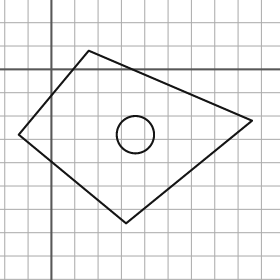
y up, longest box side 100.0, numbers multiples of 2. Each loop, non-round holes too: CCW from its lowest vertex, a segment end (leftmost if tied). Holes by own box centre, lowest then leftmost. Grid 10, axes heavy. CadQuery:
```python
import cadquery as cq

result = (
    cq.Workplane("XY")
    .moveTo(32.0, -66.0)
    .lineTo(86.0, -22.0)
    .lineTo(16.0, 8.0)
    .lineTo(-14.0, -28.0)
    .close()
    .moveTo(36.0, -28.0)
    .circle(8.0)
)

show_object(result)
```